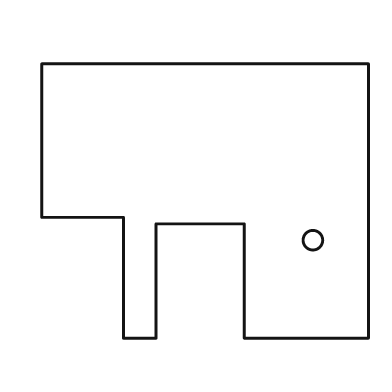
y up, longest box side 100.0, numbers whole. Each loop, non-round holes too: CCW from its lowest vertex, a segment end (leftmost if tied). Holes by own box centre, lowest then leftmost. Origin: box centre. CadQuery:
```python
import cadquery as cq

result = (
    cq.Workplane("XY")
    .moveTo(-25.0, -42.0)
    .lineTo(-15.0, -42.0)
    .lineTo(-15.0, -7.0)
    .lineTo(12.0, -7.0)
    .lineTo(12.0, -42.0)
    .lineTo(50.0, -42.0)
    .lineTo(50.0, 42.0)
    .lineTo(-50.0, 42.0)
    .lineTo(-50.0, -5.0)
    .lineTo(-25.0, -5.0)
    .close()
    .moveTo(33.0, -12.0)
    .circle(3.0)
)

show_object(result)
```